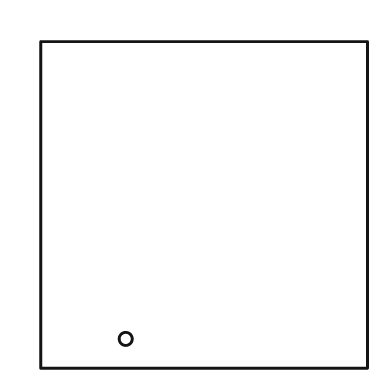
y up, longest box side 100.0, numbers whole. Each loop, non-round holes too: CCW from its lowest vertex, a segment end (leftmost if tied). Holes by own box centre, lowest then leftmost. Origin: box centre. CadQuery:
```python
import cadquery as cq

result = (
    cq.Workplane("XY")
    .moveTo(-50.0, -50.0)
    .lineTo(50.0, -50.0)
    .lineTo(50.0, 50.0)
    .lineTo(-50.0, 50.0)
    .close()
    .moveTo(-24.0, -41.0)
    .circle(2.0)
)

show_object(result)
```